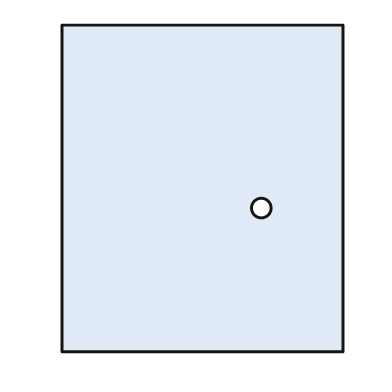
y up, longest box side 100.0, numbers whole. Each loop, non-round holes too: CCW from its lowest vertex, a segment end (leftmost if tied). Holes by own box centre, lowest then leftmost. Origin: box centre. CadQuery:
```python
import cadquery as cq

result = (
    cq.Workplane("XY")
    .moveTo(-43.0, -50.0)
    .lineTo(43.0, -50.0)
    .lineTo(43.0, 50.0)
    .lineTo(-43.0, 50.0)
    .close()
    .moveTo(18.0, -6.0)
    .circle(3.0)
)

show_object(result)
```